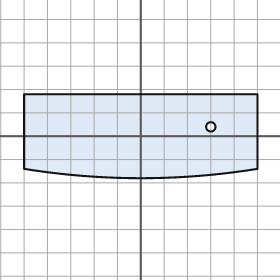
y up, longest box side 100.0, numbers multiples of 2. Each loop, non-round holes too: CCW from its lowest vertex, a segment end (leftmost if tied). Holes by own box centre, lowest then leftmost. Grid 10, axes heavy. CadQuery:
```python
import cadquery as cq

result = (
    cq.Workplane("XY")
    .moveTo(-50.0, -14.0)
    .threePointArc((0.0, -18.0), (50.0, -14.0))
    .lineTo(50.0, 18.0)
    .lineTo(-50.0, 18.0)
    .close()
    .moveTo(30.0, 4.0)
    .circle(2.0)
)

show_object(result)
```